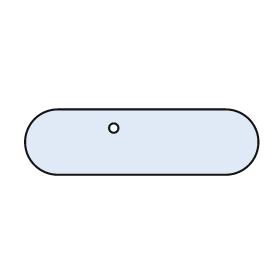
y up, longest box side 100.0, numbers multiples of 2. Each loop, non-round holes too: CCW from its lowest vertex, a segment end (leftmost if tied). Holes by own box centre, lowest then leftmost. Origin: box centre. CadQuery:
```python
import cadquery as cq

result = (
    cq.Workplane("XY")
    .moveTo(-36.0, -14.0)
    .lineTo(36.0, -14.0)
    .threePointArc((50.0, 0.0), (36.0, 14.0))
    .lineTo(-36.0, 14.0)
    .threePointArc((-50.0, 0.0), (-36.0, -14.0))
    .close()
    .moveTo(-12.0, 6.0)
    .circle(2.0)
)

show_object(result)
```